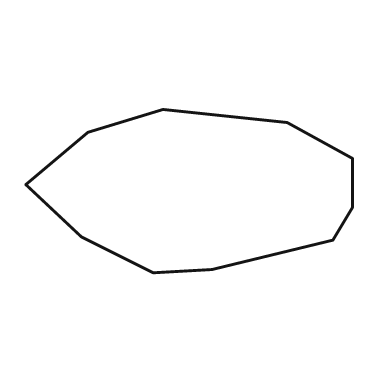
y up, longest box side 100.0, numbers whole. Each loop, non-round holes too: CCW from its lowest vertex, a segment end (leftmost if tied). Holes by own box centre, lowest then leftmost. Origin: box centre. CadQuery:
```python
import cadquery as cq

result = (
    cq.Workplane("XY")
    .moveTo(-11.0, -25.0)
    .lineTo(7.0, -24.0)
    .lineTo(44.0, -15.0)
    .lineTo(50.0, -5.0)
    .lineTo(50.0, 10.0)
    .lineTo(30.0, 21.0)
    .lineTo(-8.0, 25.0)
    .lineTo(-31.0, 18.0)
    .lineTo(-50.0, 2.0)
    .lineTo(-33.0, -14.0)
    .close()
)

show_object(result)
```